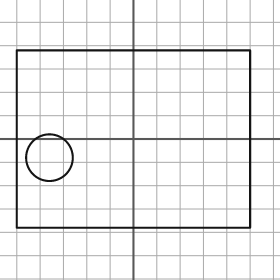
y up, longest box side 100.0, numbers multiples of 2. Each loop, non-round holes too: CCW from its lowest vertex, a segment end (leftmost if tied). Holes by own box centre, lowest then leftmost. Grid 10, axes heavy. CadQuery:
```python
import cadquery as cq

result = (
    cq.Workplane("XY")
    .moveTo(-50.0, -38.0)
    .lineTo(50.0, -38.0)
    .lineTo(50.0, 38.0)
    .lineTo(-50.0, 38.0)
    .close()
    .moveTo(-36.0, -8.0)
    .circle(10.0)
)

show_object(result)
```